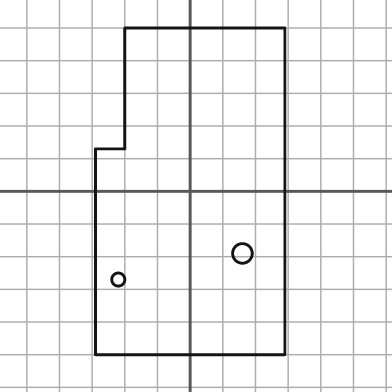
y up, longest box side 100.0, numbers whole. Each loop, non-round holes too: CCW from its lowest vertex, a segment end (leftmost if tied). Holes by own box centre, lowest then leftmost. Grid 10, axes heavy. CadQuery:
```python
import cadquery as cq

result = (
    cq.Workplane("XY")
    .moveTo(-29.0, -50.0)
    .lineTo(29.0, -50.0)
    .lineTo(29.0, 50.0)
    .lineTo(-20.0, 50.0)
    .lineTo(-20.0, 13.0)
    .lineTo(-29.0, 13.0)
    .close()
    .moveTo(-22.0, -27.0)
    .circle(2.0)
    .moveTo(16.0, -19.0)
    .circle(3.0)
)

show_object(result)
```